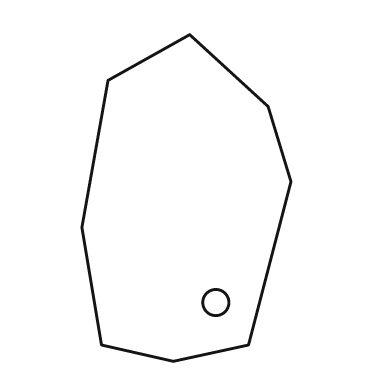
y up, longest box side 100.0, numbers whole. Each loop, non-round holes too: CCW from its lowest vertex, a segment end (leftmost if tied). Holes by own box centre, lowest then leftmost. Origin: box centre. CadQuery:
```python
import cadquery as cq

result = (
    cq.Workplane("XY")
    .moveTo(-4.0, -50.0)
    .lineTo(19.0, -45.0)
    .lineTo(32.0, 5.0)
    .lineTo(25.0, 28.0)
    .lineTo(1.0, 50.0)
    .lineTo(-24.0, 36.0)
    .lineTo(-32.0, -9.0)
    .lineTo(-26.0, -45.0)
    .close()
    .moveTo(9.0, -32.0)
    .circle(4.0)
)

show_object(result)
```